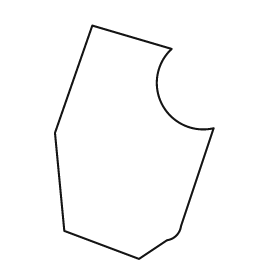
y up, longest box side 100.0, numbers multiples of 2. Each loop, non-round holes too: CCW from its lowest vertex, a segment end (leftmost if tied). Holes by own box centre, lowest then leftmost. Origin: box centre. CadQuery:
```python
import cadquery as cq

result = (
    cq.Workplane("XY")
    .moveTo(2.0, -50.0)
    .lineTo(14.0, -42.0)
    .threePointArc((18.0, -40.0), (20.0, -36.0))
    .lineTo(34.0, 6.0)
    .threePointArc((12.0, 16.0), (16.0, 40.0))
    .lineTo(-18.0, 50.0)
    .lineTo(-34.0, 4.0)
    .lineTo(-30.0, -38.0)
    .close()
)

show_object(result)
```